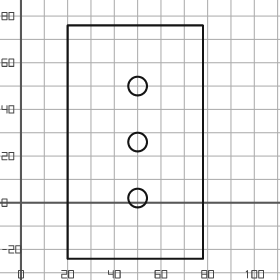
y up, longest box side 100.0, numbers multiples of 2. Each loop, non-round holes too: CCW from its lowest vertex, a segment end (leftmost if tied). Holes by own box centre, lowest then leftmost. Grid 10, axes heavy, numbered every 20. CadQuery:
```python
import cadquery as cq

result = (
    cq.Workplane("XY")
    .moveTo(20.0, -24.0)
    .lineTo(78.0, -24.0)
    .lineTo(78.0, 76.0)
    .lineTo(20.0, 76.0)
    .close()
    .moveTo(50.0, 2.0)
    .circle(4.0)
    .moveTo(50.0, 26.0)
    .circle(4.0)
    .moveTo(50.0, 50.0)
    .circle(4.0)
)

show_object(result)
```